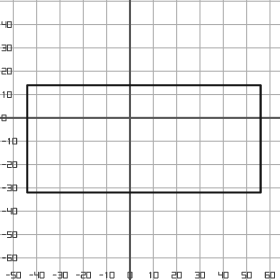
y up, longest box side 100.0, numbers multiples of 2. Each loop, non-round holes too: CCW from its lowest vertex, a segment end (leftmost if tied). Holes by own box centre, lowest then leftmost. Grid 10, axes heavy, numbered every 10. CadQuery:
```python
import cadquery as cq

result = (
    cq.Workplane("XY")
    .moveTo(-44.0, -32.0)
    .lineTo(56.0, -32.0)
    .lineTo(56.0, 14.0)
    .lineTo(-44.0, 14.0)
    .close()
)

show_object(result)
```